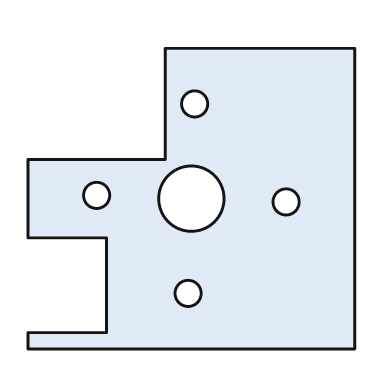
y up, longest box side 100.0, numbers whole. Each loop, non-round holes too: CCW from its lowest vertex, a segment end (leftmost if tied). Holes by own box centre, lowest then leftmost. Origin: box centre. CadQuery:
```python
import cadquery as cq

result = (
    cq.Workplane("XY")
    .moveTo(-50.0, -46.0)
    .lineTo(50.0, -46.0)
    .lineTo(50.0, 46.0)
    .lineTo(-8.0, 46.0)
    .lineTo(-8.0, 12.0)
    .lineTo(-50.0, 12.0)
    .lineTo(-50.0, -12.0)
    .lineTo(-26.0, -12.0)
    .lineTo(-26.0, -41.0)
    .lineTo(-50.0, -41.0)
    .close()
    .moveTo(-1.0, -29.0)
    .circle(4.0)
    .moveTo(29.0, -1.0)
    .circle(4.0)
    .moveTo(0.0, 0.0)
    .circle(10.0)
    .moveTo(-29.0, 1.0)
    .circle(4.0)
    .moveTo(1.0, 29.0)
    .circle(4.0)
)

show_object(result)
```